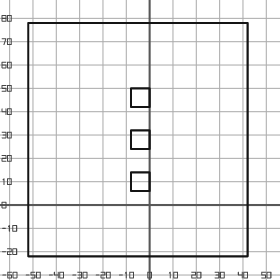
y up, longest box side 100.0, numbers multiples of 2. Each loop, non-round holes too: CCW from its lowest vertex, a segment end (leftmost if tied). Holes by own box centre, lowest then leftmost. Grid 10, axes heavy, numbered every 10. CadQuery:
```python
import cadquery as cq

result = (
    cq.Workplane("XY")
    .moveTo(-52.0, -22.0)
    .lineTo(42.0, -22.0)
    .lineTo(42.0, 78.0)
    .lineTo(-52.0, 78.0)
    .close()
    .moveTo(-8.0, 6.0)
    .lineTo(0.0, 6.0)
    .lineTo(0.0, 14.0)
    .lineTo(-8.0, 14.0)
    .close()
    .moveTo(-8.0, 24.0)
    .lineTo(0.0, 24.0)
    .lineTo(0.0, 32.0)
    .lineTo(-8.0, 32.0)
    .close()
    .moveTo(-8.0, 42.0)
    .lineTo(0.0, 42.0)
    .lineTo(0.0, 50.0)
    .lineTo(-8.0, 50.0)
    .close()
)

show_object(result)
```